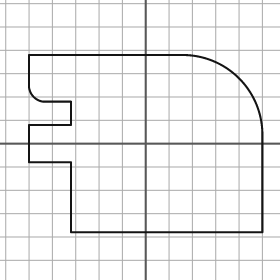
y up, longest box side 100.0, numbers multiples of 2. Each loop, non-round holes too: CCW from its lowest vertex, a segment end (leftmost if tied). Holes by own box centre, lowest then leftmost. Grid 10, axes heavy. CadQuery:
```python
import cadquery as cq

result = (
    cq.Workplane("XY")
    .moveTo(-32.0, -38.0)
    .lineTo(50.0, -38.0)
    .lineTo(50.0, 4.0)
    .threePointArc((40.0, 28.0), (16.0, 38.0))
    .lineTo(-50.0, 38.0)
    .lineTo(-50.0, 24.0)
    .threePointArc((-48.0, 20.0), (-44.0, 18.0))
    .lineTo(-32.0, 18.0)
    .lineTo(-32.0, 8.0)
    .lineTo(-50.0, 8.0)
    .lineTo(-50.0, -8.0)
    .lineTo(-32.0, -8.0)
    .close()
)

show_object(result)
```